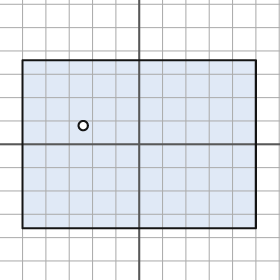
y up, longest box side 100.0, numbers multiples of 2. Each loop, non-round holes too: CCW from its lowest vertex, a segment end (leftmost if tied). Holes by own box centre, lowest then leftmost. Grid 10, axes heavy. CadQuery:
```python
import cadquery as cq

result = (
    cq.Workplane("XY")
    .moveTo(-50.0, -36.0)
    .lineTo(50.0, -36.0)
    .lineTo(50.0, 36.0)
    .lineTo(-50.0, 36.0)
    .close()
    .moveTo(-24.0, 8.0)
    .circle(2.0)
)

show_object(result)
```